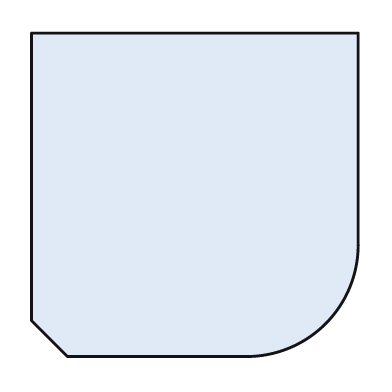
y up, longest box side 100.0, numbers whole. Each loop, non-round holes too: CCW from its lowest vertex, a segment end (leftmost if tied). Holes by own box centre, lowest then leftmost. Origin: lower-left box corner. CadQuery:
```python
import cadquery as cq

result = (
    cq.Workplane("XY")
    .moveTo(11.0, 0.0)
    .lineTo(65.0, 0.0)
    .threePointArc((90.0, 10.0), (100.0, 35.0))
    .lineTo(100.0, 99.0)
    .lineTo(0.0, 99.0)
    .lineTo(0.0, 11.0)
    .close()
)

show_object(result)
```